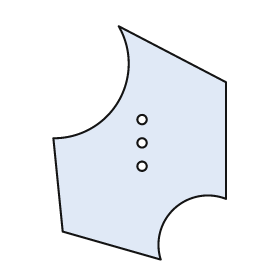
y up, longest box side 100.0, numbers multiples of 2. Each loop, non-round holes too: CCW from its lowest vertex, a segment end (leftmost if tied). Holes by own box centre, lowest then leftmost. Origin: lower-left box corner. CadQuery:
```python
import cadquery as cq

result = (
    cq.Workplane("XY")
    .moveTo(46.0, 0.0)
    .threePointArc((52.0, 22.0), (74.0, 26.0))
    .lineTo(74.0, 76.0)
    .lineTo(28.0, 100.0)
    .threePointArc((28.0, 68.0), (0.0, 52.0))
    .lineTo(4.0, 12.0)
    .close()
    .moveTo(38.0, 40.0)
    .circle(2.0)
    .moveTo(38.0, 50.0)
    .circle(2.0)
    .moveTo(38.0, 60.0)
    .circle(2.0)
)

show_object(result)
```